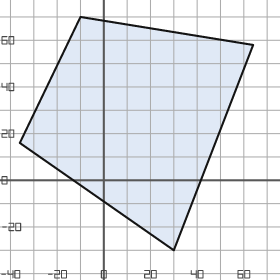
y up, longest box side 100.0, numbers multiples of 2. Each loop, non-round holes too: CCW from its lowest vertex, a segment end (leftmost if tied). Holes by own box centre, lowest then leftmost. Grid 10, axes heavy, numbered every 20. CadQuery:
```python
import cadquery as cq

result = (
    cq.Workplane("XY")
    .moveTo(30.0, -30.0)
    .lineTo(64.0, 58.0)
    .lineTo(-10.0, 70.0)
    .lineTo(-36.0, 16.0)
    .close()
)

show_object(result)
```